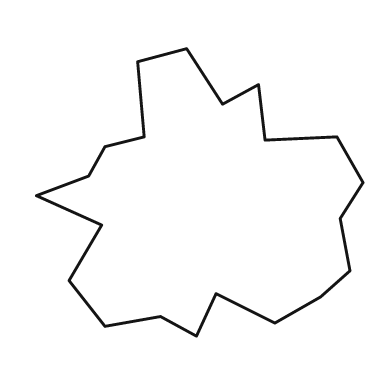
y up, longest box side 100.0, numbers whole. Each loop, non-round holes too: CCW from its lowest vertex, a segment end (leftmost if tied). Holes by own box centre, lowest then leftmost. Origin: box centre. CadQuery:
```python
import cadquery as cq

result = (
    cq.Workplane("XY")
    .moveTo(-1.0, -44.0)
    .lineTo(5.0, -31.0)
    .lineTo(23.0, -40.0)
    .lineTo(37.0, -32.0)
    .lineTo(46.0, -24.0)
    .lineTo(43.0, -8.0)
    .lineTo(50.0, 3.0)
    .lineTo(42.0, 17.0)
    .lineTo(20.0, 16.0)
    .lineTo(18.0, 33.0)
    .lineTo(7.0, 27.0)
    .lineTo(-4.0, 44.0)
    .lineTo(-19.0, 40.0)
    .lineTo(-17.0, 17.0)
    .lineTo(-29.0, 14.0)
    .lineTo(-34.0, 5.0)
    .lineTo(-50.0, -1.0)
    .lineTo(-30.0, -10.0)
    .lineTo(-40.0, -27.0)
    .lineTo(-29.0, -41.0)
    .lineTo(-12.0, -38.0)
    .close()
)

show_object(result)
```